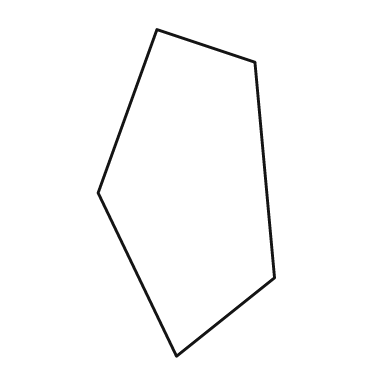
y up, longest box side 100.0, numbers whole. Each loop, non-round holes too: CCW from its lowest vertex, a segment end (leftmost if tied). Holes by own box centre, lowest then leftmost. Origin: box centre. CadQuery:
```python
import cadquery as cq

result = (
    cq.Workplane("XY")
    .moveTo(-3.0, -50.0)
    .lineTo(27.0, -26.0)
    .lineTo(21.0, 40.0)
    .lineTo(-9.0, 50.0)
    .lineTo(-27.0, 0.0)
    .close()
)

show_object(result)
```